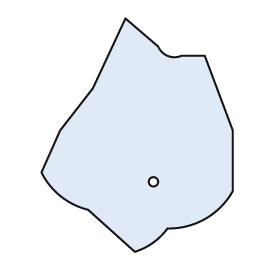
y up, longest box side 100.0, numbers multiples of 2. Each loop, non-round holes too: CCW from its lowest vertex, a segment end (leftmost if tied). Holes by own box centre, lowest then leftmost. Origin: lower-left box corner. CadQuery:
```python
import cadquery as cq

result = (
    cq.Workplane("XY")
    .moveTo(40.0, 0.0)
    .threePointArc((48.0, 4.0), (54.0, 10.0))
    .threePointArc((70.0, 14.0), (82.0, 26.0))
    .lineTo(82.0, 52.0)
    .lineTo(70.0, 84.0)
    .lineTo(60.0, 84.0)
    .threePointArc((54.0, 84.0), (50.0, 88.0))
    .lineTo(36.0, 100.0)
    .lineTo(22.0, 70.0)
    .lineTo(8.0, 52.0)
    .lineTo(0.0, 34.0)
    .threePointArc((8.0, 24.0), (20.0, 18.0))
    .close()
    .moveTo(48.0, 30.0)
    .circle(2.0)
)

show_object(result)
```